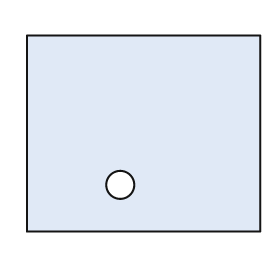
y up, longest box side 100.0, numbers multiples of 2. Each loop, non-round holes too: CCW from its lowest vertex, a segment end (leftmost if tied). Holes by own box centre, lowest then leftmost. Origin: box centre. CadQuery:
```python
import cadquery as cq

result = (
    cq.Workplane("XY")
    .moveTo(-50.0, -42.0)
    .lineTo(50.0, -42.0)
    .lineTo(50.0, 42.0)
    .lineTo(-50.0, 42.0)
    .close()
    .moveTo(-10.0, -22.0)
    .circle(6.0)
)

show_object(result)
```